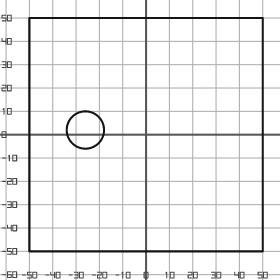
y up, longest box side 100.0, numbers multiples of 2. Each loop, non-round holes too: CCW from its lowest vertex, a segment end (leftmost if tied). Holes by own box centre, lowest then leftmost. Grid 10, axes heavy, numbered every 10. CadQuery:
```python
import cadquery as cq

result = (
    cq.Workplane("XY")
    .moveTo(-50.0, -50.0)
    .lineTo(50.0, -50.0)
    .lineTo(50.0, 50.0)
    .lineTo(-50.0, 50.0)
    .close()
    .moveTo(-26.0, 2.0)
    .circle(8.0)
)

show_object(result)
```